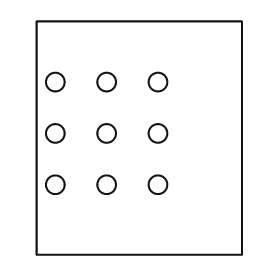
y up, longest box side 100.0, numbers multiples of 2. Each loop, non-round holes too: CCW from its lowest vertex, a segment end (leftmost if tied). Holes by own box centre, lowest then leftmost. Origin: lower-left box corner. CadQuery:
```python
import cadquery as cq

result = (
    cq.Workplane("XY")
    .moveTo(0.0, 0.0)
    .lineTo(88.0, 0.0)
    .lineTo(88.0, 100.0)
    .lineTo(0.0, 100.0)
    .close()
    .moveTo(8.0, 30.0)
    .circle(4.0)
    .moveTo(30.0, 30.0)
    .circle(4.0)
    .moveTo(52.0, 30.0)
    .circle(4.0)
    .moveTo(8.0, 52.0)
    .circle(4.0)
    .moveTo(30.0, 52.0)
    .circle(4.0)
    .moveTo(52.0, 52.0)
    .circle(4.0)
    .moveTo(8.0, 74.0)
    .circle(4.0)
    .moveTo(30.0, 74.0)
    .circle(4.0)
    .moveTo(52.0, 74.0)
    .circle(4.0)
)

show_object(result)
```